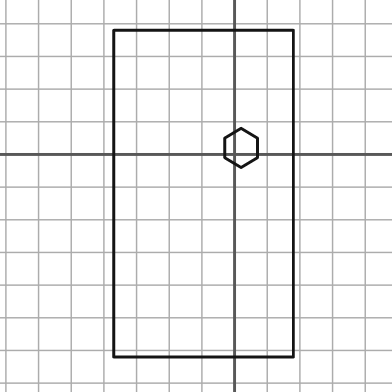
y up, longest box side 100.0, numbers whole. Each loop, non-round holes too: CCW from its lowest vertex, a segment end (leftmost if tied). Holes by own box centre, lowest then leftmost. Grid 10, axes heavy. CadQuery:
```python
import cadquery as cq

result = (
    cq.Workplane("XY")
    .moveTo(-37.0, -62.0)
    .lineTo(18.0, -62.0)
    .lineTo(18.0, 38.0)
    .lineTo(-37.0, 38.0)
    .close()
    .moveTo(2.0, -4.0)
    .lineTo(7.0, -1.0)
    .lineTo(7.0, 5.0)
    .lineTo(2.0, 8.0)
    .lineTo(-3.0, 5.0)
    .lineTo(-3.0, -1.0)
    .close()
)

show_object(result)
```